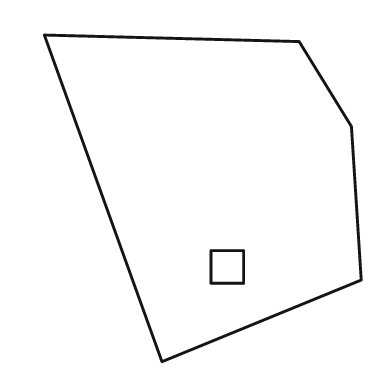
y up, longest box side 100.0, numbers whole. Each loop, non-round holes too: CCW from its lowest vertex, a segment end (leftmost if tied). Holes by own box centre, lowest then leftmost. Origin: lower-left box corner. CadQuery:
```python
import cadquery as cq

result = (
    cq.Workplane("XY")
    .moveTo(36.0, 0.0)
    .lineTo(97.0, 25.0)
    .lineTo(94.0, 72.0)
    .lineTo(78.0, 98.0)
    .lineTo(0.0, 100.0)
    .close()
    .moveTo(51.0, 24.0)
    .lineTo(61.0, 24.0)
    .lineTo(61.0, 34.0)
    .lineTo(51.0, 34.0)
    .close()
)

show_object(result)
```